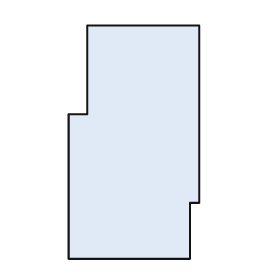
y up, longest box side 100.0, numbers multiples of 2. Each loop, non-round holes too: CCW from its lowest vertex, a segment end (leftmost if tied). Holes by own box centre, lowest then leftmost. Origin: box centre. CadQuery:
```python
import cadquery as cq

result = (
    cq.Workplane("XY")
    .moveTo(-28.0, -50.0)
    .lineTo(24.0, -50.0)
    .lineTo(24.0, -26.0)
    .lineTo(28.0, -26.0)
    .lineTo(28.0, 50.0)
    .lineTo(-20.0, 50.0)
    .lineTo(-20.0, 12.0)
    .lineTo(-28.0, 12.0)
    .close()
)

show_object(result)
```